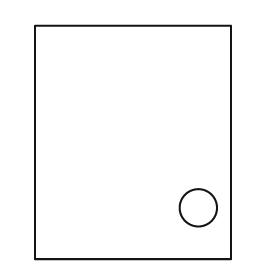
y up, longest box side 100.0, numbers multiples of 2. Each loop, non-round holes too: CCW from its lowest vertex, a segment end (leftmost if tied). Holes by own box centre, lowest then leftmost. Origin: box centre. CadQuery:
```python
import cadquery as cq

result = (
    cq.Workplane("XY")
    .moveTo(-42.0, -50.0)
    .lineTo(42.0, -50.0)
    .lineTo(42.0, 50.0)
    .lineTo(-42.0, 50.0)
    .close()
    .moveTo(28.0, -28.0)
    .circle(8.0)
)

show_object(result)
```